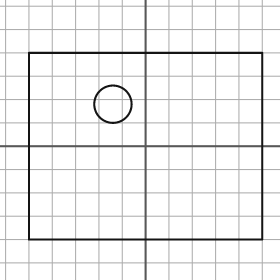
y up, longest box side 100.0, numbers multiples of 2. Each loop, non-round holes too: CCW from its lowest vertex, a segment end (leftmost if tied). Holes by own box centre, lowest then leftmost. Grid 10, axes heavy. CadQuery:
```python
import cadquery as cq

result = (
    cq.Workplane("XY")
    .moveTo(-50.0, -40.0)
    .lineTo(50.0, -40.0)
    .lineTo(50.0, 40.0)
    .lineTo(-50.0, 40.0)
    .close()
    .moveTo(-14.0, 18.0)
    .circle(8.0)
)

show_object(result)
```